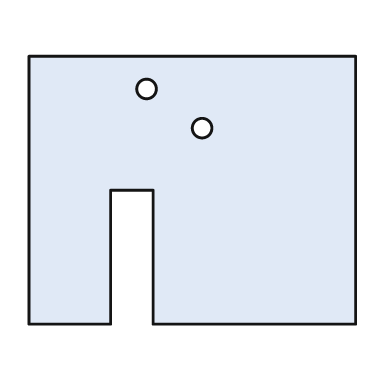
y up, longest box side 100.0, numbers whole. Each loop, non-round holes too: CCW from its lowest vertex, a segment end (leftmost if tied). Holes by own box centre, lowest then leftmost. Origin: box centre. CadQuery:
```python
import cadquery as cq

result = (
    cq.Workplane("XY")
    .moveTo(-50.0, -41.0)
    .lineTo(-25.0, -41.0)
    .lineTo(-25.0, 0.0)
    .lineTo(-12.0, 0.0)
    .lineTo(-12.0, -41.0)
    .lineTo(50.0, -41.0)
    .lineTo(50.0, 41.0)
    .lineTo(-50.0, 41.0)
    .close()
    .moveTo(3.0, 19.0)
    .circle(3.0)
    .moveTo(-14.0, 31.0)
    .circle(3.0)
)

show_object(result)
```